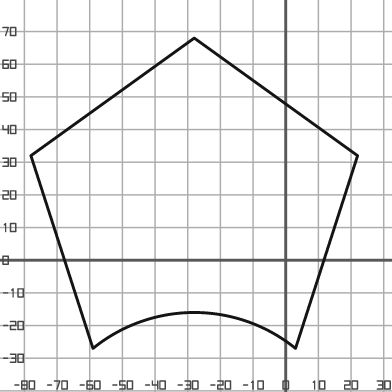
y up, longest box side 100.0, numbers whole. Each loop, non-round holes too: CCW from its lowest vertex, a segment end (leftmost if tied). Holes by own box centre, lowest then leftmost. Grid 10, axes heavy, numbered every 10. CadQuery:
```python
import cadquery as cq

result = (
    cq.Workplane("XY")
    .moveTo(-59.0, -27.0)
    .threePointArc((-28.0, -16.0), (3.0, -27.0))
    .lineTo(22.0, 32.0)
    .lineTo(-28.0, 68.0)
    .lineTo(-78.0, 32.0)
    .close()
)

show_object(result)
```